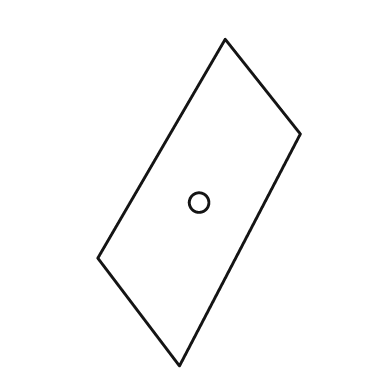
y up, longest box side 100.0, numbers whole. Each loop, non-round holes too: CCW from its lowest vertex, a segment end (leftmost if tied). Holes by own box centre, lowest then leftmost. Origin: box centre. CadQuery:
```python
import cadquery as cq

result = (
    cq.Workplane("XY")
    .moveTo(-6.0, -50.0)
    .lineTo(31.0, 21.0)
    .lineTo(8.0, 50.0)
    .lineTo(-31.0, -17.0)
    .close()
    .moveTo(0.0, 0.0)
    .circle(3.0)
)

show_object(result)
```